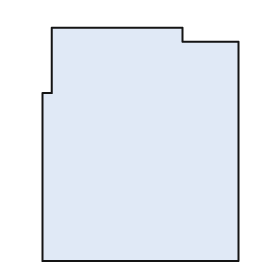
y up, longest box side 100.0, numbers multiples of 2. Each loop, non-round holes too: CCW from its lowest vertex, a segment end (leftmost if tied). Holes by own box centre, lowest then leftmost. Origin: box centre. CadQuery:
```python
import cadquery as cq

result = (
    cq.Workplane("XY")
    .moveTo(-42.0, -50.0)
    .lineTo(42.0, -50.0)
    .lineTo(42.0, 44.0)
    .lineTo(18.0, 44.0)
    .lineTo(18.0, 50.0)
    .lineTo(-38.0, 50.0)
    .lineTo(-38.0, 22.0)
    .lineTo(-42.0, 22.0)
    .close()
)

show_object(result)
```